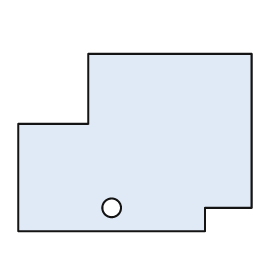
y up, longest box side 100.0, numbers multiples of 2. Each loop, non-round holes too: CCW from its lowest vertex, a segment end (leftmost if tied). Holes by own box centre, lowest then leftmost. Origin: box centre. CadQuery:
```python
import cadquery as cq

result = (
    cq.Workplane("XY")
    .moveTo(-50.0, -38.0)
    .lineTo(30.0, -38.0)
    .lineTo(30.0, -28.0)
    .lineTo(50.0, -28.0)
    .lineTo(50.0, 38.0)
    .lineTo(-20.0, 38.0)
    .lineTo(-20.0, 8.0)
    .lineTo(-50.0, 8.0)
    .close()
    .moveTo(-10.0, -28.0)
    .circle(4.0)
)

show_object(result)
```